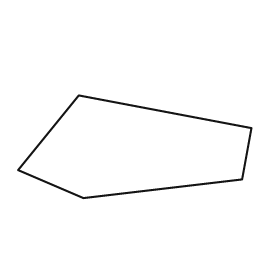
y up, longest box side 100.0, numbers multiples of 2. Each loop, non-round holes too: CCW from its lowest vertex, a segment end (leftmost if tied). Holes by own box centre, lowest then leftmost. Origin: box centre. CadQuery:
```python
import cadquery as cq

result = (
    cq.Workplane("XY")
    .moveTo(-22.0, -22.0)
    .lineTo(46.0, -14.0)
    .lineTo(50.0, 8.0)
    .lineTo(-24.0, 22.0)
    .lineTo(-50.0, -10.0)
    .close()
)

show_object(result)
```